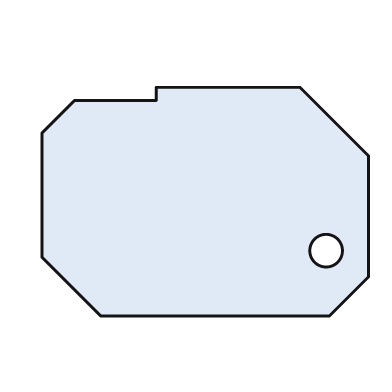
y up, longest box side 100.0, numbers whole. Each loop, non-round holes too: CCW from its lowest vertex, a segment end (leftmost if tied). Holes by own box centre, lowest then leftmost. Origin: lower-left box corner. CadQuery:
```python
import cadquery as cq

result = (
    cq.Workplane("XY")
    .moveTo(18.0, 0.0)
    .lineTo(88.0, 0.0)
    .lineTo(100.0, 12.0)
    .lineTo(100.0, 49.0)
    .lineTo(79.0, 70.0)
    .lineTo(35.0, 70.0)
    .lineTo(35.0, 66.0)
    .lineTo(10.0, 66.0)
    .lineTo(0.0, 56.0)
    .lineTo(0.0, 18.0)
    .close()
    .moveTo(87.0, 20.0)
    .circle(5.0)
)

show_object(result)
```